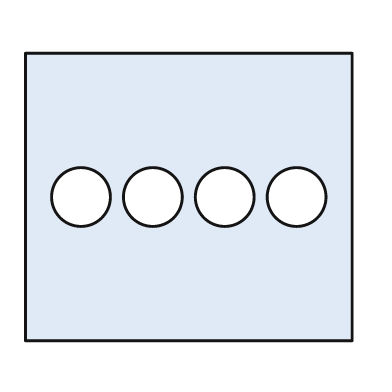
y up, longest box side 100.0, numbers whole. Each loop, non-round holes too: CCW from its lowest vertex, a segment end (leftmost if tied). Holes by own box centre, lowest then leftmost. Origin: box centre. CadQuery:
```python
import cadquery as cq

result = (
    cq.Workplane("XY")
    .moveTo(-50.0, -44.0)
    .lineTo(50.0, -44.0)
    .lineTo(50.0, 44.0)
    .lineTo(-50.0, 44.0)
    .close()
    .moveTo(-33.0, 0.0)
    .circle(9.0)
    .moveTo(-11.0, 0.0)
    .circle(9.0)
    .moveTo(11.0, 0.0)
    .circle(9.0)
    .moveTo(33.0, 0.0)
    .circle(9.0)
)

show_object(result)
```